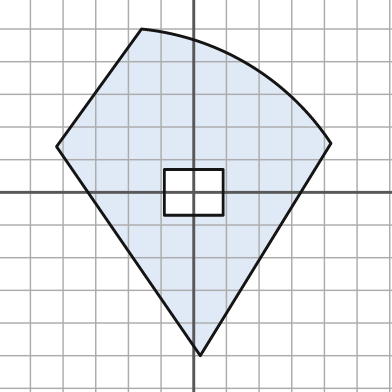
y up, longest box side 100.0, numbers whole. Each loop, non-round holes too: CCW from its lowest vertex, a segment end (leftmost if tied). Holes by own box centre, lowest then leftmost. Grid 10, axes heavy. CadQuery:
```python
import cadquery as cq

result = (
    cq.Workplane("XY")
    .moveTo(2.0, -50.0)
    .lineTo(42.0, 15.0)
    .threePointArc((17.0, 39.0), (-16.0, 50.0))
    .lineTo(-42.0, 14.0)
    .close()
    .moveTo(-9.0, -7.0)
    .lineTo(9.0, -7.0)
    .lineTo(9.0, 7.0)
    .lineTo(-9.0, 7.0)
    .close()
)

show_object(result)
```